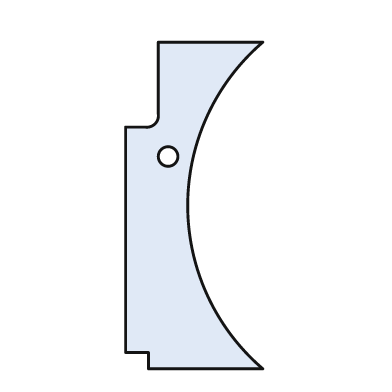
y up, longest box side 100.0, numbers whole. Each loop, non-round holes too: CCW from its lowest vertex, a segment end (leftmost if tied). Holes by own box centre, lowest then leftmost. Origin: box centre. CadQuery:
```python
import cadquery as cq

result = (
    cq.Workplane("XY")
    .moveTo(-14.0, -50.0)
    .lineTo(21.0, -50.0)
    .threePointArc((-2.0, 0.0), (21.0, 50.0))
    .lineTo(-11.0, 50.0)
    .lineTo(-11.0, 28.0)
    .threePointArc((-12.0, 25.0), (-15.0, 24.0))
    .lineTo(-21.0, 24.0)
    .lineTo(-21.0, -45.0)
    .lineTo(-14.0, -45.0)
    .close()
    .moveTo(-8.0, 15.0)
    .circle(3.0)
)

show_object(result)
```